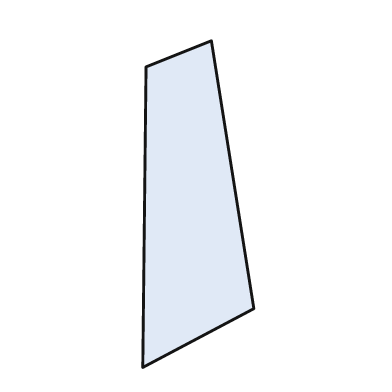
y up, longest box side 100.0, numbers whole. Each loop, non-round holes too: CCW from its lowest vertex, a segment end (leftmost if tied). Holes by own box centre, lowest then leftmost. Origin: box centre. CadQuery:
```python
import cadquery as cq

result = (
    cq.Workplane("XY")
    .moveTo(-17.0, -50.0)
    .lineTo(17.0, -32.0)
    .lineTo(4.0, 50.0)
    .lineTo(-16.0, 42.0)
    .close()
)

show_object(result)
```